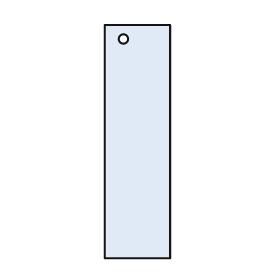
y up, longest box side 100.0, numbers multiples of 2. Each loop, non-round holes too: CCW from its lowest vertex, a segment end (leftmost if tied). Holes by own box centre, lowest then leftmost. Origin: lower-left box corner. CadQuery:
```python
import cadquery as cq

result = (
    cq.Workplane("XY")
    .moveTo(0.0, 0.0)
    .lineTo(28.0, 0.0)
    .lineTo(28.0, 100.0)
    .lineTo(0.0, 100.0)
    .close()
    .moveTo(8.0, 94.0)
    .circle(2.0)
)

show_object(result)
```